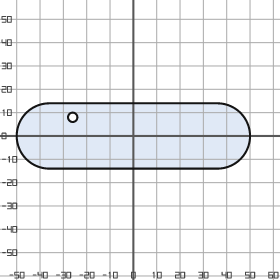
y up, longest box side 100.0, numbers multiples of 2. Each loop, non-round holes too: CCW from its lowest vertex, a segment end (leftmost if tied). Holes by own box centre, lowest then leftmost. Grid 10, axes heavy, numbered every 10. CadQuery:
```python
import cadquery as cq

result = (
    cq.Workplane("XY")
    .moveTo(-36.0, -14.0)
    .lineTo(36.0, -14.0)
    .threePointArc((50.0, 0.0), (36.0, 14.0))
    .lineTo(-36.0, 14.0)
    .threePointArc((-50.0, 0.0), (-36.0, -14.0))
    .close()
    .moveTo(-26.0, 8.0)
    .circle(2.0)
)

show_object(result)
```